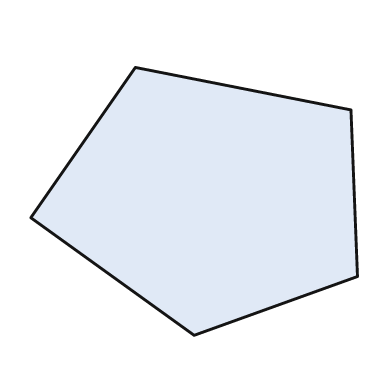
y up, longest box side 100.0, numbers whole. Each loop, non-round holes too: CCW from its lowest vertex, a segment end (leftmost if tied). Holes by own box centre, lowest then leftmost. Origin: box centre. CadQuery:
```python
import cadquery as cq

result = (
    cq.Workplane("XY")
    .moveTo(0.0, -41.0)
    .lineTo(50.0, -23.0)
    .lineTo(48.0, 28.0)
    .lineTo(-18.0, 41.0)
    .lineTo(-50.0, -5.0)
    .close()
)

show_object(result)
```